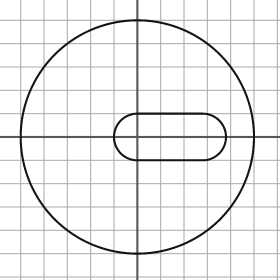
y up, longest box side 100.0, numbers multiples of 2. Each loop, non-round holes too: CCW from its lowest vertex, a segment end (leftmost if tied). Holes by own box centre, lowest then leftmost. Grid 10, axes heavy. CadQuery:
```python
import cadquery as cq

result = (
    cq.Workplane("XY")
    .moveTo(0.0, 0.0)
    .circle(50.0)
    .moveTo(0.0, -10.0)
    .lineTo(28.0, -10.0)
    .threePointArc((38.0, 0.0), (28.0, 10.0))
    .lineTo(0.0, 10.0)
    .threePointArc((-10.0, 0.0), (0.0, -10.0))
    .close()
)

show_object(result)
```